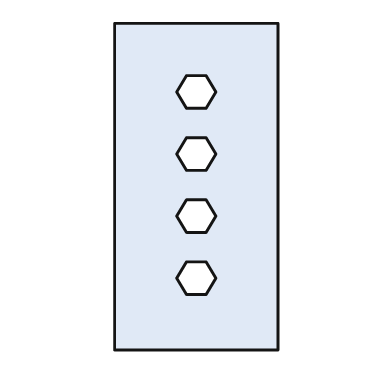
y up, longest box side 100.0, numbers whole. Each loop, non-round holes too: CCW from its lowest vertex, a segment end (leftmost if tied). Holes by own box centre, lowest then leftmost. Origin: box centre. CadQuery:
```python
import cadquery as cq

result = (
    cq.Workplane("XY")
    .moveTo(-25.0, -50.0)
    .lineTo(25.0, -50.0)
    .lineTo(25.0, 50.0)
    .lineTo(-25.0, 50.0)
    .close()
    .moveTo(-3.0, -33.0)
    .lineTo(3.0, -33.0)
    .lineTo(6.0, -28.0)
    .lineTo(3.0, -23.0)
    .lineTo(-3.0, -23.0)
    .lineTo(-6.0, -28.0)
    .close()
    .moveTo(-3.0, -14.0)
    .lineTo(3.0, -14.0)
    .lineTo(6.0, -9.0)
    .lineTo(3.0, -4.0)
    .lineTo(-3.0, -4.0)
    .lineTo(-6.0, -9.0)
    .close()
    .moveTo(-3.0, 5.0)
    .lineTo(3.0, 5.0)
    .lineTo(6.0, 10.0)
    .lineTo(3.0, 15.0)
    .lineTo(-3.0, 15.0)
    .lineTo(-6.0, 10.0)
    .close()
    .moveTo(-3.0, 24.0)
    .lineTo(3.0, 24.0)
    .lineTo(6.0, 29.0)
    .lineTo(3.0, 34.0)
    .lineTo(-3.0, 34.0)
    .lineTo(-6.0, 29.0)
    .close()
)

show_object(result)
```